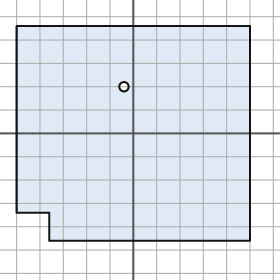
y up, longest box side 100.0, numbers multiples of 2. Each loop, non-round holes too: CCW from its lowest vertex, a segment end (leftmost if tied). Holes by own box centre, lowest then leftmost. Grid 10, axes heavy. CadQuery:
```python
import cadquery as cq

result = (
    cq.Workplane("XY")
    .moveTo(-36.0, -46.0)
    .lineTo(50.0, -46.0)
    .lineTo(50.0, 46.0)
    .lineTo(-50.0, 46.0)
    .lineTo(-50.0, -34.0)
    .lineTo(-36.0, -34.0)
    .close()
    .moveTo(-4.0, 20.0)
    .circle(2.0)
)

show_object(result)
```